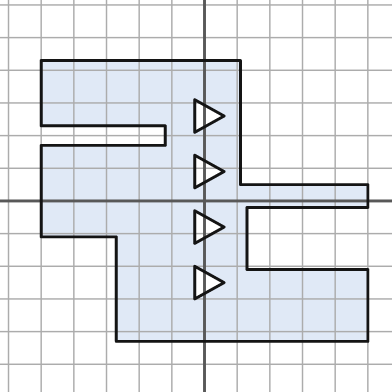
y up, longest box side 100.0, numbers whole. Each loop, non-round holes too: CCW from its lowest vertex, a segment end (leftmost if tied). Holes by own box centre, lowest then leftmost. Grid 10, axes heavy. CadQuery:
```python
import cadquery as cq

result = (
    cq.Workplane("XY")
    .moveTo(-27.0, -43.0)
    .lineTo(50.0, -43.0)
    .lineTo(50.0, -21.0)
    .lineTo(13.0, -21.0)
    .lineTo(13.0, -2.0)
    .lineTo(50.0, -2.0)
    .lineTo(50.0, 5.0)
    .lineTo(11.0, 5.0)
    .lineTo(11.0, 43.0)
    .lineTo(-50.0, 43.0)
    .lineTo(-50.0, 23.0)
    .lineTo(-12.0, 23.0)
    .lineTo(-12.0, 17.0)
    .lineTo(-50.0, 17.0)
    .lineTo(-50.0, -11.0)
    .lineTo(-27.0, -11.0)
    .close()
    .moveTo(-3.0, -30.0)
    .lineTo(6.0, -25.0)
    .lineTo(-3.0, -20.0)
    .close()
    .moveTo(-3.0, -13.0)
    .lineTo(6.0, -8.0)
    .lineTo(-3.0, -3.0)
    .close()
    .moveTo(-3.0, 4.0)
    .lineTo(6.0, 9.0)
    .lineTo(-3.0, 14.0)
    .close()
    .moveTo(-3.0, 21.0)
    .lineTo(6.0, 26.0)
    .lineTo(-3.0, 31.0)
    .close()
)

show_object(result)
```